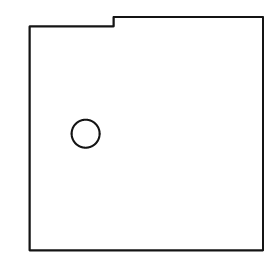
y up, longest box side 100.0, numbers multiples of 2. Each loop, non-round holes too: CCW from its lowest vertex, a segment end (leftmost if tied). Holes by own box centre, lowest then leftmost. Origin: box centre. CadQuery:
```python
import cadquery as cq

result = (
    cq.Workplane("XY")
    .moveTo(-50.0, -50.0)
    .lineTo(50.0, -50.0)
    .lineTo(50.0, 50.0)
    .lineTo(-14.0, 50.0)
    .lineTo(-14.0, 46.0)
    .lineTo(-50.0, 46.0)
    .close()
    .moveTo(-26.0, 0.0)
    .circle(6.0)
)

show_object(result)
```